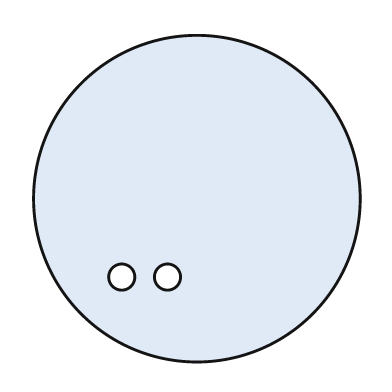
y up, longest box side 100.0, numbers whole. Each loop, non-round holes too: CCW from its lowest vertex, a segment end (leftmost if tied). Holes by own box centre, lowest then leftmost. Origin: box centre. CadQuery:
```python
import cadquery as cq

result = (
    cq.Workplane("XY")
    .moveTo(0.0, 0.0)
    .circle(50.0)
    .moveTo(-23.0, -24.0)
    .circle(4.0)
    .moveTo(-9.0, -24.0)
    .circle(4.0)
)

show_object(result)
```